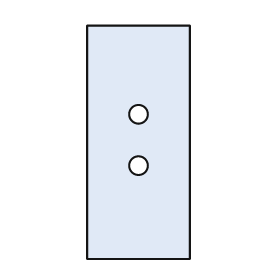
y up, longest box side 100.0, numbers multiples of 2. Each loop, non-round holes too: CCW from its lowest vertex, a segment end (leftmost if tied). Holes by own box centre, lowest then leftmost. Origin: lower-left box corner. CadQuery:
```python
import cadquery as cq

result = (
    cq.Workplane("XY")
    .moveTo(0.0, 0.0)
    .lineTo(44.0, 0.0)
    .lineTo(44.0, 100.0)
    .lineTo(0.0, 100.0)
    .close()
    .moveTo(22.0, 40.0)
    .circle(4.0)
    .moveTo(22.0, 62.0)
    .circle(4.0)
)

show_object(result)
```